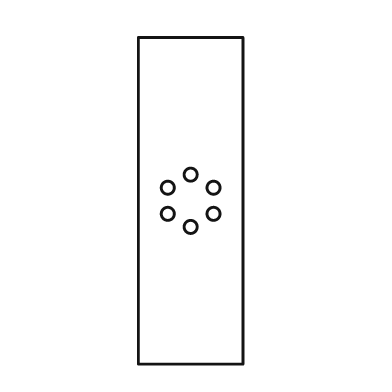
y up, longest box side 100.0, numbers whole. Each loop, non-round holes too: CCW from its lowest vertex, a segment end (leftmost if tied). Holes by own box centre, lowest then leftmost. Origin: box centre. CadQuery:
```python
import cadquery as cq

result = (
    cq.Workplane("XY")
    .moveTo(-16.0, -50.0)
    .lineTo(16.0, -50.0)
    .lineTo(16.0, 50.0)
    .lineTo(-16.0, 50.0)
    .close()
    .moveTo(0.0, -8.0)
    .circle(2.0)
    .moveTo(-7.0, -4.0)
    .circle(2.0)
    .moveTo(7.0, -4.0)
    .circle(2.0)
    .moveTo(-7.0, 4.0)
    .circle(2.0)
    .moveTo(7.0, 4.0)
    .circle(2.0)
    .moveTo(0.0, 8.0)
    .circle(2.0)
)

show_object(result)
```